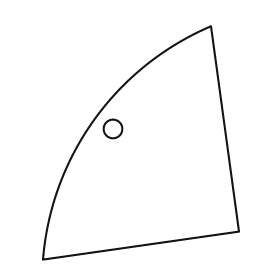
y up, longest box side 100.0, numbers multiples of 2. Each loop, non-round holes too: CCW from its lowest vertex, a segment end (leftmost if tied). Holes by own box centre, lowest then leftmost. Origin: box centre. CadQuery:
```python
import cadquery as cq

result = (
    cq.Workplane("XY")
    .moveTo(-42.0, -50.0)
    .lineTo(42.0, -38.0)
    .lineTo(30.0, 50.0)
    .threePointArc((-20.0, 10.0), (-42.0, -50.0))
    .close()
    .moveTo(-12.0, 6.0)
    .circle(4.0)
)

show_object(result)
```